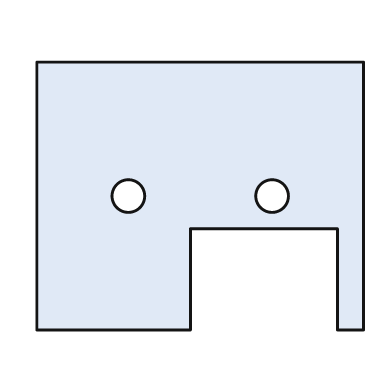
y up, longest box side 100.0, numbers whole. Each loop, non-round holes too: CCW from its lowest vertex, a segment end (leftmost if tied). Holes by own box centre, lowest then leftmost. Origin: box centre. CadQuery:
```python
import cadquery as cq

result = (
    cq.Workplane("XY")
    .moveTo(-50.0, -41.0)
    .lineTo(-3.0, -41.0)
    .lineTo(-3.0, -10.0)
    .lineTo(42.0, -10.0)
    .lineTo(42.0, -41.0)
    .lineTo(50.0, -41.0)
    .lineTo(50.0, 41.0)
    .lineTo(-50.0, 41.0)
    .close()
    .moveTo(-22.0, 0.0)
    .circle(5.0)
    .moveTo(22.0, 0.0)
    .circle(5.0)
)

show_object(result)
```